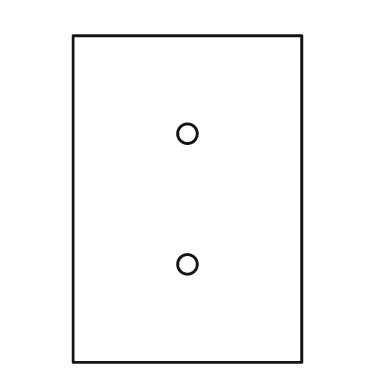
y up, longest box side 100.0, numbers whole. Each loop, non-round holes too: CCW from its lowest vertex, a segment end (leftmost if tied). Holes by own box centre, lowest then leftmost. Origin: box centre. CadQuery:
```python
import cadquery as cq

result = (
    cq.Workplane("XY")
    .moveTo(-35.0, -50.0)
    .lineTo(35.0, -50.0)
    .lineTo(35.0, 50.0)
    .lineTo(-35.0, 50.0)
    .close()
    .moveTo(0.0, -20.0)
    .circle(3.0)
    .moveTo(0.0, 20.0)
    .circle(3.0)
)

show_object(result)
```